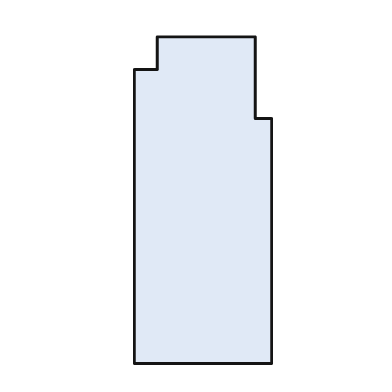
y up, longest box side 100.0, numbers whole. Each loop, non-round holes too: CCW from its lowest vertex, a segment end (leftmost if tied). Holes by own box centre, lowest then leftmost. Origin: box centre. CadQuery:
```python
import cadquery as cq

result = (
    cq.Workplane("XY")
    .moveTo(-21.0, -50.0)
    .lineTo(21.0, -50.0)
    .lineTo(21.0, 25.0)
    .lineTo(16.0, 25.0)
    .lineTo(16.0, 50.0)
    .lineTo(-14.0, 50.0)
    .lineTo(-14.0, 40.0)
    .lineTo(-21.0, 40.0)
    .close()
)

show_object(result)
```